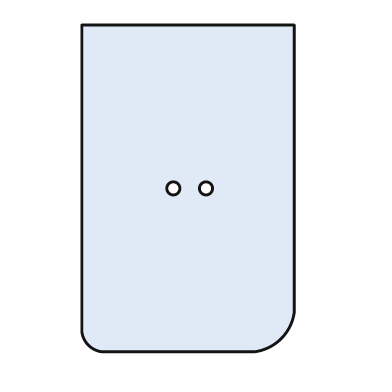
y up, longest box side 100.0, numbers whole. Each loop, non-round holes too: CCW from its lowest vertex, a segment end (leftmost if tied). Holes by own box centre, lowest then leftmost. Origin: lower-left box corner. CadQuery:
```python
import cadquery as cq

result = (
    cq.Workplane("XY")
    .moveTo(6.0, 0.0)
    .lineTo(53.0, 0.0)
    .threePointArc((61.0, 4.0), (65.0, 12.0))
    .lineTo(65.0, 100.0)
    .lineTo(0.0, 100.0)
    .lineTo(0.0, 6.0)
    .threePointArc((2.0, 2.0), (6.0, 0.0))
    .close()
    .moveTo(28.0, 50.0)
    .circle(2.0)
    .moveTo(38.0, 50.0)
    .circle(2.0)
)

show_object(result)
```